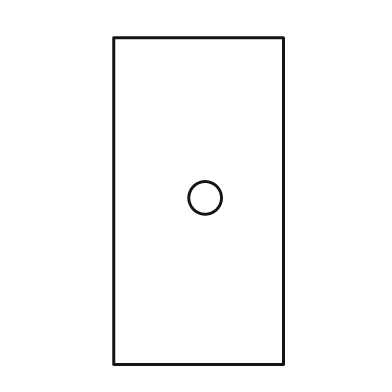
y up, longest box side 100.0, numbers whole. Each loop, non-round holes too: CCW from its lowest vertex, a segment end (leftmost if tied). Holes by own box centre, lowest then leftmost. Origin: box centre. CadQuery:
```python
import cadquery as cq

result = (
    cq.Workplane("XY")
    .moveTo(-26.0, -50.0)
    .lineTo(26.0, -50.0)
    .lineTo(26.0, 50.0)
    .lineTo(-26.0, 50.0)
    .close()
    .moveTo(2.0, 1.0)
    .circle(5.0)
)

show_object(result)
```